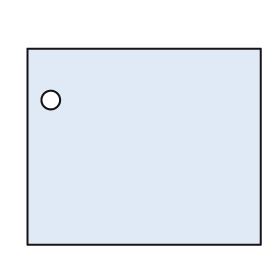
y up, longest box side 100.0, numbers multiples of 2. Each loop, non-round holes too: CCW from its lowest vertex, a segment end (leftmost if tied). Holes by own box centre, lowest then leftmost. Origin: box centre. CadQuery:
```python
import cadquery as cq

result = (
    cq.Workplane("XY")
    .moveTo(-50.0, -42.0)
    .lineTo(50.0, -42.0)
    .lineTo(50.0, 42.0)
    .lineTo(-50.0, 42.0)
    .close()
    .moveTo(-40.0, 20.0)
    .circle(4.0)
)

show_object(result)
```